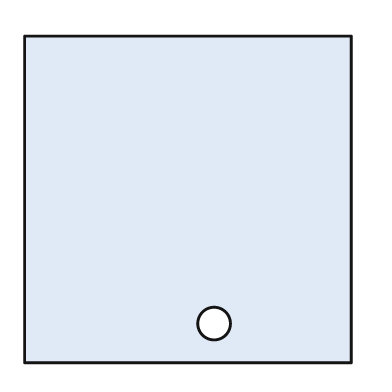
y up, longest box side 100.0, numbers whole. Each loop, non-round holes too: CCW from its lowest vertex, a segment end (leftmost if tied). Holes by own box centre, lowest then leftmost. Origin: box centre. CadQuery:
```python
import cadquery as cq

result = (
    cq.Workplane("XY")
    .moveTo(-50.0, -50.0)
    .lineTo(50.0, -50.0)
    .lineTo(50.0, 50.0)
    .lineTo(-50.0, 50.0)
    .close()
    .moveTo(8.0, -38.0)
    .circle(5.0)
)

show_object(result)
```